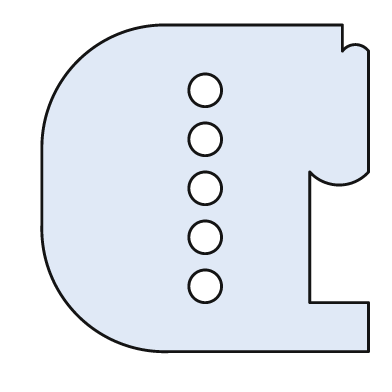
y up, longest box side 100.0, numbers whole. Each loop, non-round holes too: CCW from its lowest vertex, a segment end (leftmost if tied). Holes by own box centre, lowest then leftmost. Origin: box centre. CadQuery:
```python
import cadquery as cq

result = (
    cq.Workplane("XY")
    .moveTo(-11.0, -50.0)
    .lineTo(50.0, -50.0)
    .lineTo(50.0, -35.0)
    .lineTo(32.0, -35.0)
    .lineTo(32.0, 5.0)
    .threePointArc((41.0, 1.0), (50.0, 5.0))
    .lineTo(50.0, 42.0)
    .threePointArc((46.0, 44.0), (42.0, 42.0))
    .lineTo(42.0, 50.0)
    .lineTo(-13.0, 50.0)
    .threePointArc((-39.0, 39.0), (-50.0, 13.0))
    .lineTo(-50.0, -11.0)
    .threePointArc((-39.0, -39.0), (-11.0, -50.0))
    .close()
    .moveTo(0.0, -30.0)
    .circle(5.0)
    .moveTo(0.0, -15.0)
    .circle(5.0)
    .moveTo(0.0, 0.0)
    .circle(5.0)
    .moveTo(0.0, 15.0)
    .circle(5.0)
    .moveTo(0.0, 30.0)
    .circle(5.0)
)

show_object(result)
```